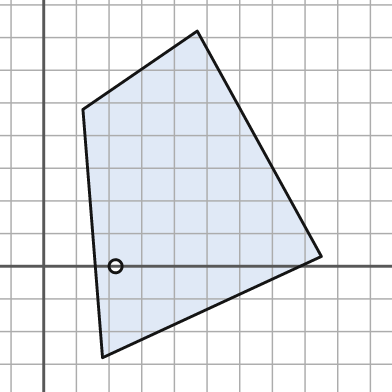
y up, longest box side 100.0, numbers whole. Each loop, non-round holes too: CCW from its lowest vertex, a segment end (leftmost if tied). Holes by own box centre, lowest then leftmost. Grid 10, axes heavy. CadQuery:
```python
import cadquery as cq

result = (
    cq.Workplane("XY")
    .moveTo(18.0, -28.0)
    .lineTo(85.0, 3.0)
    .lineTo(47.0, 72.0)
    .lineTo(12.0, 48.0)
    .close()
    .moveTo(22.0, 0.0)
    .circle(2.0)
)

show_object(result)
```